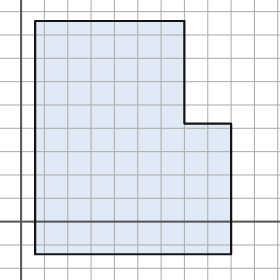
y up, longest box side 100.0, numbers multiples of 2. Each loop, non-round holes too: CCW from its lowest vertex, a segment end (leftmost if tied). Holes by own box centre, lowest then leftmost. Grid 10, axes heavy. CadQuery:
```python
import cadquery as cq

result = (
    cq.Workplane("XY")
    .moveTo(6.0, -14.0)
    .lineTo(90.0, -14.0)
    .lineTo(90.0, 42.0)
    .lineTo(70.0, 42.0)
    .lineTo(70.0, 86.0)
    .lineTo(6.0, 86.0)
    .close()
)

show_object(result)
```